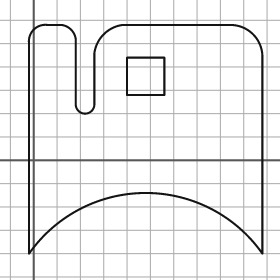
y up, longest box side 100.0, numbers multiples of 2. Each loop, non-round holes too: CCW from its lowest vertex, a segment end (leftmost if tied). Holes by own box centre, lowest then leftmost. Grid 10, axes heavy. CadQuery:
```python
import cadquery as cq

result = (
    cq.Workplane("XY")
    .moveTo(-2.0, -40.0)
    .threePointArc((48.0, -14.0), (98.0, -40.0))
    .lineTo(98.0, 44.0)
    .threePointArc((94.0, 54.0), (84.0, 58.0))
    .lineTo(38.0, 58.0)
    .threePointArc((30.0, 54.0), (26.0, 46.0))
    .lineTo(26.0, 24.0)
    .threePointArc((22.0, 20.0), (18.0, 24.0))
    .lineTo(18.0, 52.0)
    .threePointArc((16.0, 56.0), (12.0, 58.0))
    .lineTo(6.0, 58.0)
    .threePointArc((0.0, 56.0), (-2.0, 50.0))
    .close()
    .moveTo(40.0, 28.0)
    .lineTo(56.0, 28.0)
    .lineTo(56.0, 44.0)
    .lineTo(40.0, 44.0)
    .close()
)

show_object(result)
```